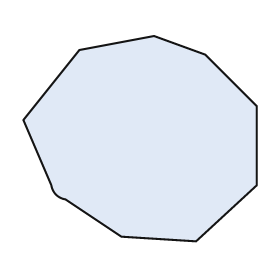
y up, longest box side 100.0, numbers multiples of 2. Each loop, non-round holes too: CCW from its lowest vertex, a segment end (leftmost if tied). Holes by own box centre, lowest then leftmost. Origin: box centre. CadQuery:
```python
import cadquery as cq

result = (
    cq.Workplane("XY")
    .moveTo(24.0, -44.0)
    .lineTo(50.0, -20.0)
    .lineTo(50.0, 14.0)
    .lineTo(28.0, 36.0)
    .lineTo(6.0, 44.0)
    .lineTo(-26.0, 38.0)
    .lineTo(-50.0, 8.0)
    .lineTo(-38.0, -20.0)
    .threePointArc((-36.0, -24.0), (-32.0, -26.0))
    .lineTo(-8.0, -42.0)
    .close()
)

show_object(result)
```